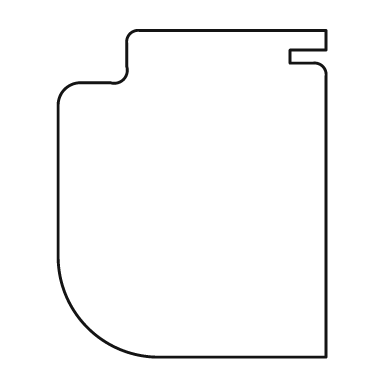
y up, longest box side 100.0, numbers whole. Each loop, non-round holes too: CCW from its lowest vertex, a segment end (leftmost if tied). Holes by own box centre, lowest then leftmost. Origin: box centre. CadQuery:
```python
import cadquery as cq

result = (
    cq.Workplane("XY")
    .moveTo(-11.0, -50.0)
    .lineTo(41.0, -50.0)
    .lineTo(41.0, 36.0)
    .threePointArc((40.0, 39.0), (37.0, 40.0))
    .lineTo(30.0, 40.0)
    .lineTo(30.0, 44.0)
    .lineTo(41.0, 44.0)
    .lineTo(41.0, 50.0)
    .lineTo(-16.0, 50.0)
    .threePointArc((-19.0, 49.0), (-20.0, 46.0))
    .lineTo(-20.0, 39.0)
    .threePointArc((-21.0, 35.0), (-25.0, 34.0))
    .lineTo(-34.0, 34.0)
    .threePointArc((-39.0, 32.0), (-41.0, 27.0))
    .lineTo(-41.0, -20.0)
    .threePointArc((-32.0, -41.0), (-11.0, -50.0))
    .close()
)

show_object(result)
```